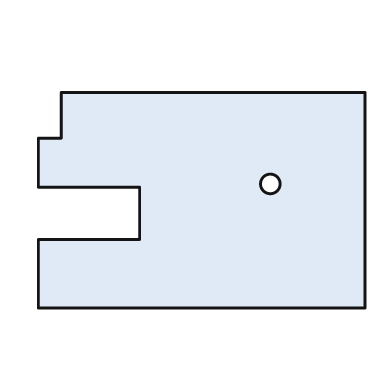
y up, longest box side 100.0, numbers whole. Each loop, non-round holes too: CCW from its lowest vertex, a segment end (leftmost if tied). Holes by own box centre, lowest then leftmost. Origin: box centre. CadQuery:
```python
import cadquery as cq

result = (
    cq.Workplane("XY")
    .moveTo(-50.0, -33.0)
    .lineTo(50.0, -33.0)
    .lineTo(50.0, 33.0)
    .lineTo(-43.0, 33.0)
    .lineTo(-43.0, 19.0)
    .lineTo(-50.0, 19.0)
    .lineTo(-50.0, 4.0)
    .lineTo(-19.0, 4.0)
    .lineTo(-19.0, -12.0)
    .lineTo(-50.0, -12.0)
    .close()
    .moveTo(21.0, 5.0)
    .circle(3.0)
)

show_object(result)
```